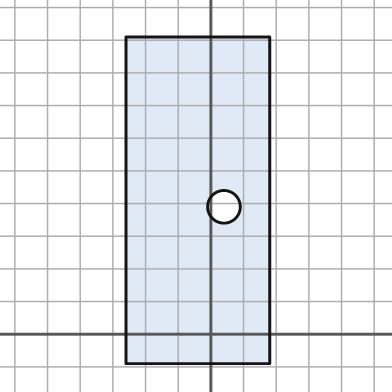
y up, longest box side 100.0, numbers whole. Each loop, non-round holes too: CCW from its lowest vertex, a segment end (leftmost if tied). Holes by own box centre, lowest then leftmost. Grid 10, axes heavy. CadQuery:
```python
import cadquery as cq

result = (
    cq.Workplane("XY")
    .moveTo(-26.0, -9.0)
    .lineTo(18.0, -9.0)
    .lineTo(18.0, 91.0)
    .lineTo(-26.0, 91.0)
    .close()
    .moveTo(4.0, 39.0)
    .circle(5.0)
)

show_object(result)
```